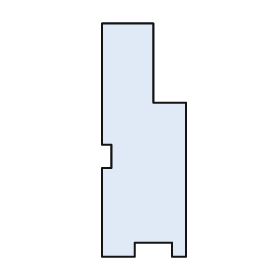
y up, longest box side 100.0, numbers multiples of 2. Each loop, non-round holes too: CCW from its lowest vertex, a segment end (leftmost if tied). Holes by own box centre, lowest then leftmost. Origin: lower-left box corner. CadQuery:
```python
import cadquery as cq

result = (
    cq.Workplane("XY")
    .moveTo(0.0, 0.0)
    .lineTo(14.0, 0.0)
    .lineTo(14.0, 6.0)
    .lineTo(30.0, 6.0)
    .lineTo(30.0, 0.0)
    .lineTo(36.0, 0.0)
    .lineTo(36.0, 66.0)
    .lineTo(22.0, 66.0)
    .lineTo(22.0, 100.0)
    .lineTo(0.0, 100.0)
    .lineTo(0.0, 48.0)
    .lineTo(4.0, 48.0)
    .lineTo(4.0, 38.0)
    .lineTo(0.0, 38.0)
    .close()
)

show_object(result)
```